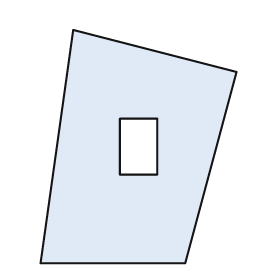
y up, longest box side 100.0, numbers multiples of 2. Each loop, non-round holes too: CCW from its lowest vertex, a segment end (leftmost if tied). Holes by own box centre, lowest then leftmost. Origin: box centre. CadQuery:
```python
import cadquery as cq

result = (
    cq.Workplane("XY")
    .moveTo(-42.0, -50.0)
    .lineTo(20.0, -50.0)
    .lineTo(42.0, 32.0)
    .lineTo(-28.0, 50.0)
    .close()
    .moveTo(-8.0, -12.0)
    .lineTo(8.0, -12.0)
    .lineTo(8.0, 12.0)
    .lineTo(-8.0, 12.0)
    .close()
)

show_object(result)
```